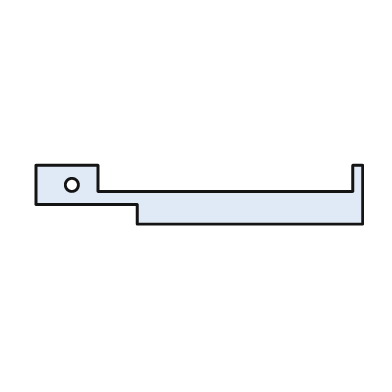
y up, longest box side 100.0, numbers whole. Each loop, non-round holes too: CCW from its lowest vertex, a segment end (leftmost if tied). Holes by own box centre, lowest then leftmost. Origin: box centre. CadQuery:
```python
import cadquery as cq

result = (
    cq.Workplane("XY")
    .moveTo(-19.0, -9.0)
    .lineTo(50.0, -9.0)
    .lineTo(50.0, 9.0)
    .lineTo(47.0, 9.0)
    .lineTo(47.0, 1.0)
    .lineTo(-31.0, 1.0)
    .lineTo(-31.0, 9.0)
    .lineTo(-50.0, 9.0)
    .lineTo(-50.0, -3.0)
    .lineTo(-19.0, -3.0)
    .close()
    .moveTo(-39.0, 3.0)
    .circle(2.0)
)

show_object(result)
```